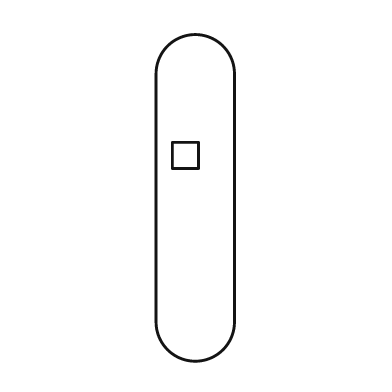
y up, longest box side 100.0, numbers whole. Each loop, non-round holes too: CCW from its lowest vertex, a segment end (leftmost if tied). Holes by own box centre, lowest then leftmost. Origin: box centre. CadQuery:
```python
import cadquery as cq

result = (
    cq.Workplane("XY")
    .moveTo(-12.0, -38.0)
    .threePointArc((0.0, -50.0), (12.0, -38.0))
    .lineTo(12.0, 38.0)
    .threePointArc((0.0, 50.0), (-12.0, 38.0))
    .close()
    .moveTo(-7.0, 9.0)
    .lineTo(1.0, 9.0)
    .lineTo(1.0, 17.0)
    .lineTo(-7.0, 17.0)
    .close()
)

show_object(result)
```